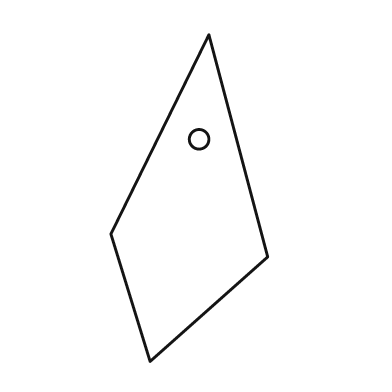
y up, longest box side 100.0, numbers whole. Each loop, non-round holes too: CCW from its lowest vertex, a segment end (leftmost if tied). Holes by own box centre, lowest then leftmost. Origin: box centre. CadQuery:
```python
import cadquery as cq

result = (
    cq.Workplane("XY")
    .moveTo(-12.0, -50.0)
    .lineTo(24.0, -18.0)
    .lineTo(6.0, 50.0)
    .lineTo(-24.0, -11.0)
    .close()
    .moveTo(3.0, 18.0)
    .circle(3.0)
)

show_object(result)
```